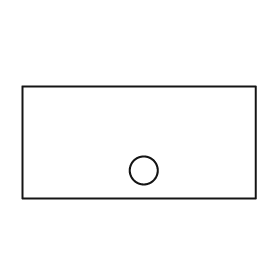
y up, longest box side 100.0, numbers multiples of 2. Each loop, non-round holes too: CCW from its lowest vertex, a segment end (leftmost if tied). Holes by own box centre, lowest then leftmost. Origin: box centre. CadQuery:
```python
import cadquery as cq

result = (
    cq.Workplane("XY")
    .moveTo(-50.0, -24.0)
    .lineTo(50.0, -24.0)
    .lineTo(50.0, 24.0)
    .lineTo(-50.0, 24.0)
    .close()
    .moveTo(2.0, -12.0)
    .circle(6.0)
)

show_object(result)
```